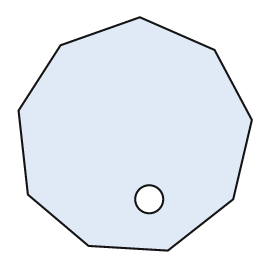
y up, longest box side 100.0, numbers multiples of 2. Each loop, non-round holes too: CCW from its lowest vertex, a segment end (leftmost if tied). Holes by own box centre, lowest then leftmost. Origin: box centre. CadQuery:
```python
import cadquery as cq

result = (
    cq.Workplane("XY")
    .moveTo(14.0, -50.0)
    .lineTo(42.0, -28.0)
    .lineTo(50.0, 6.0)
    .lineTo(34.0, 36.0)
    .lineTo(2.0, 50.0)
    .lineTo(-32.0, 38.0)
    .lineTo(-50.0, 10.0)
    .lineTo(-46.0, -26.0)
    .lineTo(-20.0, -48.0)
    .close()
    .moveTo(6.0, -28.0)
    .circle(6.0)
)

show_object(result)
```